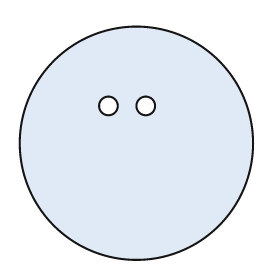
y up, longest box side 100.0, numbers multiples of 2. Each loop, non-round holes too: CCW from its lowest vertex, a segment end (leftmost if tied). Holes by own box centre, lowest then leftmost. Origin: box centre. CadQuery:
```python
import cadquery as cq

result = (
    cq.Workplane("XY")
    .moveTo(0.0, 0.0)
    .circle(50.0)
    .moveTo(-12.0, 16.0)
    .circle(4.0)
    .moveTo(4.0, 16.0)
    .circle(4.0)
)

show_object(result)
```